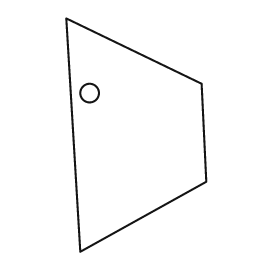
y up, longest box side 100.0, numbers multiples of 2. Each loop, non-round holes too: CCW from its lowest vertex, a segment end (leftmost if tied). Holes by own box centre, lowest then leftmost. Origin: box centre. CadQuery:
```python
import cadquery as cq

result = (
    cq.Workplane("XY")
    .moveTo(-24.0, -50.0)
    .lineTo(30.0, -20.0)
    .lineTo(28.0, 22.0)
    .lineTo(-30.0, 50.0)
    .close()
    .moveTo(-20.0, 18.0)
    .circle(4.0)
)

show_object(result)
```